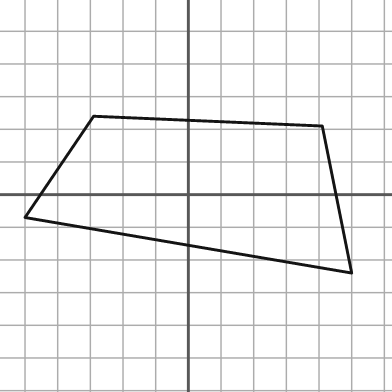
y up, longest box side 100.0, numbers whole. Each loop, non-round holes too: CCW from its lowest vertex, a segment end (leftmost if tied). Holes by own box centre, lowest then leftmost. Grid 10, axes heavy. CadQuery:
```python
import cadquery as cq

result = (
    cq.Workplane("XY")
    .moveTo(50.0, -24.0)
    .lineTo(41.0, 21.0)
    .lineTo(-29.0, 24.0)
    .lineTo(-50.0, -7.0)
    .close()
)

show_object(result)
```